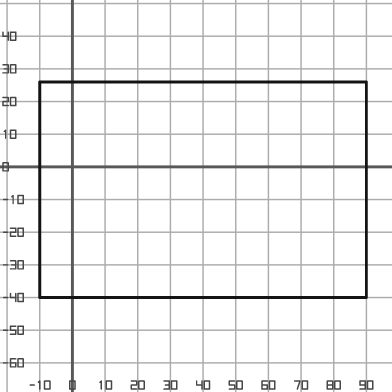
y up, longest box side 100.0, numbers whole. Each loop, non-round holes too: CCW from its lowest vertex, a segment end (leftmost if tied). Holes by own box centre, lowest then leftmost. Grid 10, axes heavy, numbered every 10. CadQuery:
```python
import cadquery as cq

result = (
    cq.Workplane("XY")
    .moveTo(-10.0, -40.0)
    .lineTo(90.0, -40.0)
    .lineTo(90.0, 26.0)
    .lineTo(-10.0, 26.0)
    .close()
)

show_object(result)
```